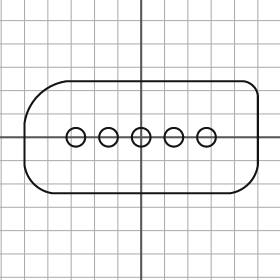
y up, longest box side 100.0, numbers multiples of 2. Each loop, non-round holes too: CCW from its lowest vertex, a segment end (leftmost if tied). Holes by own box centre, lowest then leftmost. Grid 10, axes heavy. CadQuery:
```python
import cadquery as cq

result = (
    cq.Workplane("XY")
    .moveTo(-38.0, -24.0)
    .lineTo(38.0, -24.0)
    .threePointArc((46.0, -20.0), (50.0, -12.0))
    .lineTo(50.0, 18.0)
    .threePointArc((48.0, 22.0), (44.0, 24.0))
    .lineTo(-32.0, 24.0)
    .threePointArc((-44.0, 18.0), (-50.0, 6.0))
    .lineTo(-50.0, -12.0)
    .threePointArc((-46.0, -20.0), (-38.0, -24.0))
    .close()
    .moveTo(-28.0, 0.0)
    .circle(4.0)
    .moveTo(-14.0, 0.0)
    .circle(4.0)
    .moveTo(0.0, 0.0)
    .circle(4.0)
    .moveTo(14.0, 0.0)
    .circle(4.0)
    .moveTo(28.0, 0.0)
    .circle(4.0)
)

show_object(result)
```